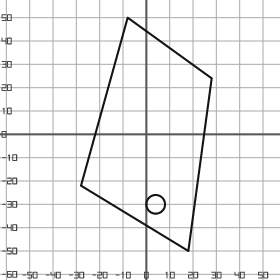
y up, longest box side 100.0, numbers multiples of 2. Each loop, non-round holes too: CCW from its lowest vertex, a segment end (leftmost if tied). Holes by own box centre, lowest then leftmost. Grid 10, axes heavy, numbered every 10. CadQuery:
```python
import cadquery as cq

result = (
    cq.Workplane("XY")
    .moveTo(18.0, -50.0)
    .lineTo(28.0, 24.0)
    .lineTo(-8.0, 50.0)
    .lineTo(-28.0, -22.0)
    .close()
    .moveTo(4.0, -30.0)
    .circle(4.0)
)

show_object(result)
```